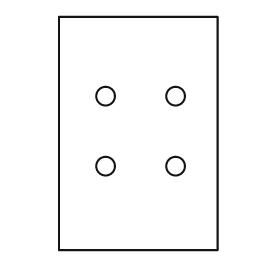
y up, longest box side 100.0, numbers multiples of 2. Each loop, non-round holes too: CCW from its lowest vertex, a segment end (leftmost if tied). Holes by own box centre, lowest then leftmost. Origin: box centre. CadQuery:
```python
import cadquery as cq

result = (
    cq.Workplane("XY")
    .moveTo(-34.0, -50.0)
    .lineTo(34.0, -50.0)
    .lineTo(34.0, 50.0)
    .lineTo(-34.0, 50.0)
    .close()
    .moveTo(-14.0, -14.0)
    .circle(4.0)
    .moveTo(16.0, -14.0)
    .circle(4.0)
    .moveTo(-14.0, 16.0)
    .circle(4.0)
    .moveTo(16.0, 16.0)
    .circle(4.0)
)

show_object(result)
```